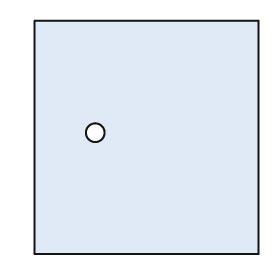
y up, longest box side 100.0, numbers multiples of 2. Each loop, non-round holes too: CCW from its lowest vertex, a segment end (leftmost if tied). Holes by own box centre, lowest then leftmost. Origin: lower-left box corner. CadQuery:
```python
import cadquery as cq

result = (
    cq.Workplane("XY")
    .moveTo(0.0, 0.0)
    .lineTo(96.0, 0.0)
    .lineTo(96.0, 100.0)
    .lineTo(0.0, 100.0)
    .close()
    .moveTo(26.0, 52.0)
    .circle(4.0)
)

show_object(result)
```